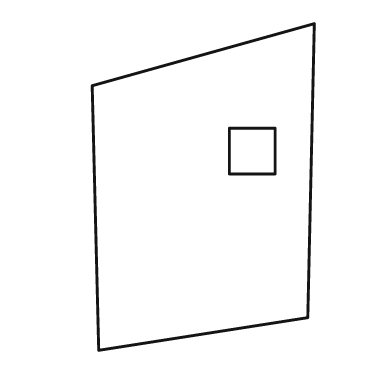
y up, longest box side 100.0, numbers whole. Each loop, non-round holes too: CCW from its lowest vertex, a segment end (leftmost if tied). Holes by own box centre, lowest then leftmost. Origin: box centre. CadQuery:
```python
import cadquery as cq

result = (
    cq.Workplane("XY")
    .moveTo(-32.0, -50.0)
    .lineTo(32.0, -40.0)
    .lineTo(34.0, 50.0)
    .lineTo(-34.0, 31.0)
    .close()
    .moveTo(8.0, 4.0)
    .lineTo(22.0, 4.0)
    .lineTo(22.0, 18.0)
    .lineTo(8.0, 18.0)
    .close()
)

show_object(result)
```